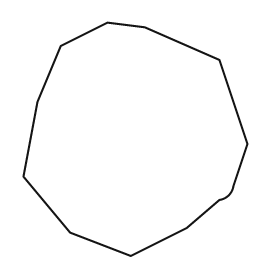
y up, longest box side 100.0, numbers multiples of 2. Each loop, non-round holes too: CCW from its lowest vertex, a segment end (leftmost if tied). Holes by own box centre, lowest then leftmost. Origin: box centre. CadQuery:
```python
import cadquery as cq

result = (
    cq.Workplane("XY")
    .moveTo(-2.0, -50.0)
    .lineTo(22.0, -38.0)
    .lineTo(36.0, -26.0)
    .threePointArc((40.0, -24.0), (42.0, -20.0))
    .lineTo(48.0, -2.0)
    .lineTo(36.0, 34.0)
    .lineTo(4.0, 48.0)
    .lineTo(-12.0, 50.0)
    .lineTo(-32.0, 40.0)
    .lineTo(-42.0, 16.0)
    .lineTo(-48.0, -16.0)
    .lineTo(-28.0, -40.0)
    .close()
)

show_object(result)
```